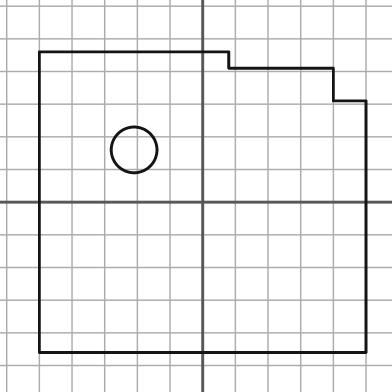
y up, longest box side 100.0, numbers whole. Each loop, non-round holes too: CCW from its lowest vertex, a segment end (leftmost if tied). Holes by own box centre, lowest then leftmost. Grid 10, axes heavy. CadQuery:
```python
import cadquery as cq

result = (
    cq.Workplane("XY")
    .moveTo(-50.0, -46.0)
    .lineTo(50.0, -46.0)
    .lineTo(50.0, 31.0)
    .lineTo(40.0, 31.0)
    .lineTo(40.0, 41.0)
    .lineTo(8.0, 41.0)
    .lineTo(8.0, 46.0)
    .lineTo(-50.0, 46.0)
    .close()
    .moveTo(-21.0, 16.0)
    .circle(7.0)
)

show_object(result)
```